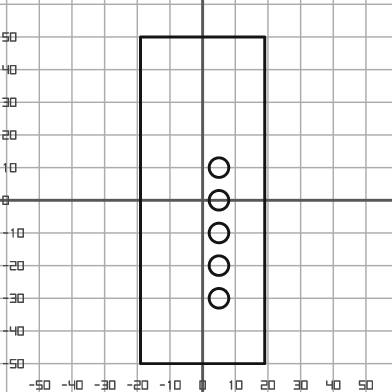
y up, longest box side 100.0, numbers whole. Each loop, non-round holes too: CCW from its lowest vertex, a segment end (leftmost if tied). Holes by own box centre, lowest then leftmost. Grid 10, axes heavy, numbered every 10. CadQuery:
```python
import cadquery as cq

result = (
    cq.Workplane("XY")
    .moveTo(-19.0, -50.0)
    .lineTo(19.0, -50.0)
    .lineTo(19.0, 50.0)
    .lineTo(-19.0, 50.0)
    .close()
    .moveTo(5.0, -30.0)
    .circle(3.0)
    .moveTo(5.0, -20.0)
    .circle(3.0)
    .moveTo(5.0, -10.0)
    .circle(3.0)
    .moveTo(5.0, 0.0)
    .circle(3.0)
    .moveTo(5.0, 10.0)
    .circle(3.0)
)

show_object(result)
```